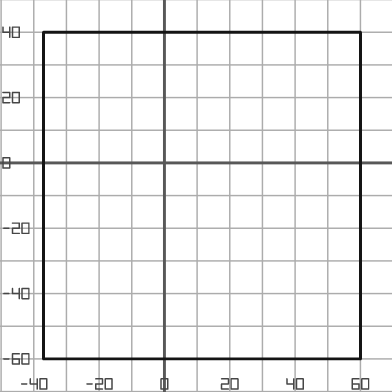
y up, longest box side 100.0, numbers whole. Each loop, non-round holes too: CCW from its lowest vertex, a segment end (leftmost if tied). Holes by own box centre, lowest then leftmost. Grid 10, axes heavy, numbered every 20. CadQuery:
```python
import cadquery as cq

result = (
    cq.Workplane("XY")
    .moveTo(-37.0, -60.0)
    .lineTo(60.0, -60.0)
    .lineTo(60.0, 40.0)
    .lineTo(-37.0, 40.0)
    .close()
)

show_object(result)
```